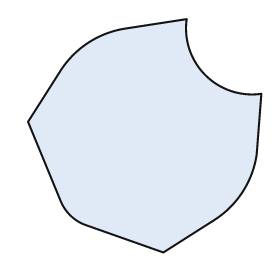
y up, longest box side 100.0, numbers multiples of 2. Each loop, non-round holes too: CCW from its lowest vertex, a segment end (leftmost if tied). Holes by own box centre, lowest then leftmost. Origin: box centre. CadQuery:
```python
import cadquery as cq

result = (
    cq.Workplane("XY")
    .moveTo(8.0, -50.0)
    .lineTo(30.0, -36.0)
    .threePointArc((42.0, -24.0), (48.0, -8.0))
    .lineTo(50.0, 18.0)
    .threePointArc((26.0, 26.0), (18.0, 50.0))
    .lineTo(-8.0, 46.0)
    .threePointArc((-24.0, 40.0), (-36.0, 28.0))
    .lineTo(-50.0, 6.0)
    .lineTo(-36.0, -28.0)
    .threePointArc((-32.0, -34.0), (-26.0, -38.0))
    .close()
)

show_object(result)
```